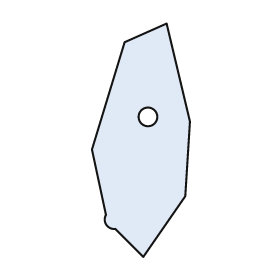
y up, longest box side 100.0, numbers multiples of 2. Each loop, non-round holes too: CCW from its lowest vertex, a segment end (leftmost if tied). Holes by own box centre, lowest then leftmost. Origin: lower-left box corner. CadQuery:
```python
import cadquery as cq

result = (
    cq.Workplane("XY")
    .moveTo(22.0, 0.0)
    .lineTo(40.0, 26.0)
    .lineTo(42.0, 58.0)
    .lineTo(32.0, 100.0)
    .lineTo(14.0, 92.0)
    .lineTo(0.0, 46.0)
    .lineTo(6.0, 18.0)
    .threePointArc((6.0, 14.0), (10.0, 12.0))
    .close()
    .moveTo(24.0, 60.0)
    .circle(4.0)
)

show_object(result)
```